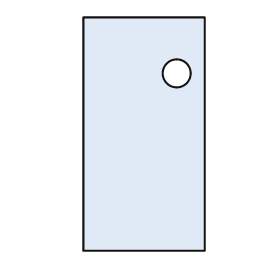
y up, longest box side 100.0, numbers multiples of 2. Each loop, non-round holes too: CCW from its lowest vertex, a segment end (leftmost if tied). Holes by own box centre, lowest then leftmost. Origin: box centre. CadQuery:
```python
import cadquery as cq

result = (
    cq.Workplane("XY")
    .moveTo(-26.0, -50.0)
    .lineTo(26.0, -50.0)
    .lineTo(26.0, 50.0)
    .lineTo(-26.0, 50.0)
    .close()
    .moveTo(14.0, 26.0)
    .circle(6.0)
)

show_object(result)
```